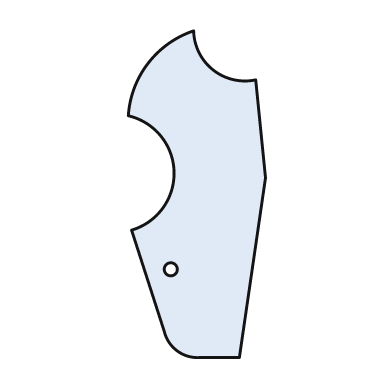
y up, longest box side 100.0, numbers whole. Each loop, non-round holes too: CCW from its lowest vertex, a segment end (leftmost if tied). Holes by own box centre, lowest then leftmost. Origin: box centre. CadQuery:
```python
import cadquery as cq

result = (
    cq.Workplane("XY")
    .moveTo(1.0, -50.0)
    .lineTo(13.0, -50.0)
    .lineTo(21.0, 5.0)
    .lineTo(18.0, 35.0)
    .threePointArc((5.0, 38.0), (-1.0, 50.0))
    .threePointArc((-15.0, 40.0), (-21.0, 24.0))
    .threePointArc((-7.0, 7.0), (-20.0, -11.0))
    .lineTo(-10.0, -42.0)
    .threePointArc((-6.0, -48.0), (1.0, -50.0))
    .close()
    .moveTo(-8.0, -23.0)
    .circle(2.0)
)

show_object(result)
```